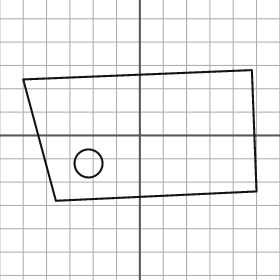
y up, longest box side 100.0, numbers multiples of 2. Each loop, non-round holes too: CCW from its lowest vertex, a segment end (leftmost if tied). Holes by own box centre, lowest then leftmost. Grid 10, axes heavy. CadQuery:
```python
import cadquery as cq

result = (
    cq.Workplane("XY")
    .moveTo(-36.0, -28.0)
    .lineTo(50.0, -24.0)
    .lineTo(48.0, 28.0)
    .lineTo(-50.0, 24.0)
    .close()
    .moveTo(-22.0, -12.0)
    .circle(6.0)
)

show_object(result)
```